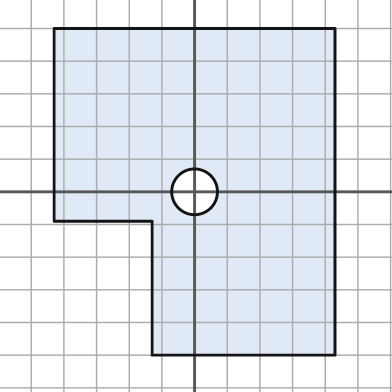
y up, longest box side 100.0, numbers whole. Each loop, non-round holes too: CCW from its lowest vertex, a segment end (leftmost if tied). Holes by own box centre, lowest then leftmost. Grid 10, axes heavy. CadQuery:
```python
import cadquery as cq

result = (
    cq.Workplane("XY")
    .moveTo(-13.0, -50.0)
    .lineTo(43.0, -50.0)
    .lineTo(43.0, 50.0)
    .lineTo(-43.0, 50.0)
    .lineTo(-43.0, -9.0)
    .lineTo(-13.0, -9.0)
    .close()
    .moveTo(0.0, 0.0)
    .circle(7.0)
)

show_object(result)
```